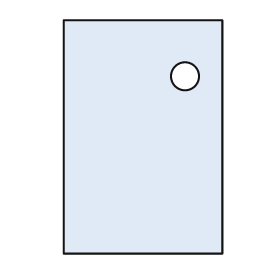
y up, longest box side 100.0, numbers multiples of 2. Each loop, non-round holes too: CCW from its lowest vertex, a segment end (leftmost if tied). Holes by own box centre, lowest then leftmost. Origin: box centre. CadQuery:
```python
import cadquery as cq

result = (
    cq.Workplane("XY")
    .moveTo(-34.0, -50.0)
    .lineTo(34.0, -50.0)
    .lineTo(34.0, 50.0)
    .lineTo(-34.0, 50.0)
    .close()
    .moveTo(18.0, 26.0)
    .circle(6.0)
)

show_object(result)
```